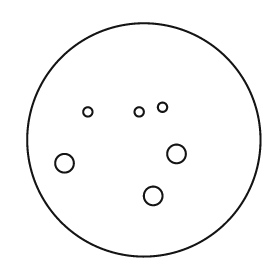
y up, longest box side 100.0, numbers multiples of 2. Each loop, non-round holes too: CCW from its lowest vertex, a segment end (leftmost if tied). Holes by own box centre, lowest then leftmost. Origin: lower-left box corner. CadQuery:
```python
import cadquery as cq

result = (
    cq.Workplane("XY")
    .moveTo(50.0, 50.0)
    .circle(50.0)
    .moveTo(54.0, 26.0)
    .circle(4.0)
    .moveTo(16.0, 40.0)
    .circle(4.0)
    .moveTo(64.0, 44.0)
    .circle(4.0)
    .moveTo(26.0, 62.0)
    .circle(2.0)
    .moveTo(48.0, 62.0)
    .circle(2.0)
    .moveTo(58.0, 64.0)
    .circle(2.0)
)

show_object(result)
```